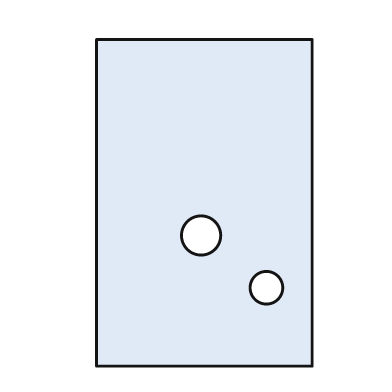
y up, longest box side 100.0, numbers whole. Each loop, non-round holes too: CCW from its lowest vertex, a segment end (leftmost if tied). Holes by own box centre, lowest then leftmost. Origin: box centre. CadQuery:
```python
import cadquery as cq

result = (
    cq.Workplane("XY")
    .moveTo(-33.0, -50.0)
    .lineTo(33.0, -50.0)
    .lineTo(33.0, 50.0)
    .lineTo(-33.0, 50.0)
    .close()
    .moveTo(19.0, -26.0)
    .circle(5.0)
    .moveTo(-1.0, -10.0)
    .circle(6.0)
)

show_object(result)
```